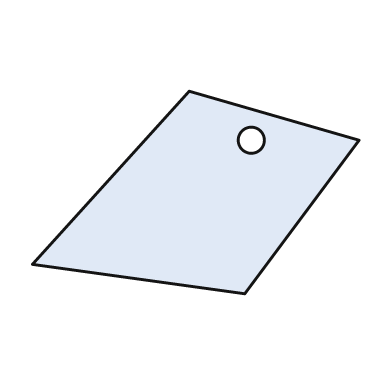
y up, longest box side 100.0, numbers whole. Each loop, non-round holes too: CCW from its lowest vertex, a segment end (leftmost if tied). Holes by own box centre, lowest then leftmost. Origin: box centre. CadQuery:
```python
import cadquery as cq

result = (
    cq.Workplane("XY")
    .moveTo(15.0, -31.0)
    .lineTo(50.0, 16.0)
    .lineTo(-2.0, 31.0)
    .lineTo(-50.0, -22.0)
    .close()
    .moveTo(17.0, 16.0)
    .circle(4.0)
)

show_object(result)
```